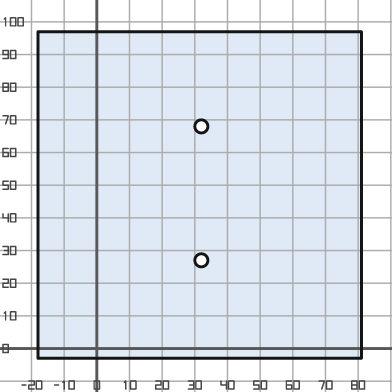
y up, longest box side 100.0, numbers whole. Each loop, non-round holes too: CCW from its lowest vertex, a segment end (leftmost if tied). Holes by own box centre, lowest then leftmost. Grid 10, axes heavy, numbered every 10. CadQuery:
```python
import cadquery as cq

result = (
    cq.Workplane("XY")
    .moveTo(-18.0, -3.0)
    .lineTo(81.0, -3.0)
    .lineTo(81.0, 97.0)
    .lineTo(-18.0, 97.0)
    .close()
    .moveTo(32.0, 27.0)
    .circle(2.0)
    .moveTo(32.0, 68.0)
    .circle(2.0)
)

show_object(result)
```